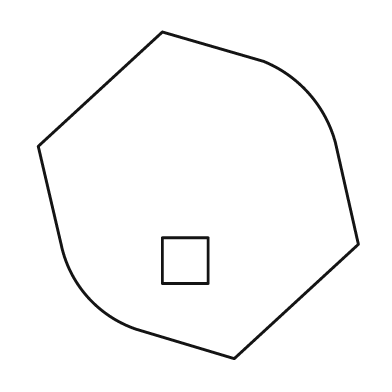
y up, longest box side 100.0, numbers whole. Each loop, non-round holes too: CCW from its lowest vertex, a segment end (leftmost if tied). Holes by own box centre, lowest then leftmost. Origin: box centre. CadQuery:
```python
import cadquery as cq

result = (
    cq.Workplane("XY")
    .moveTo(11.0, -50.0)
    .lineTo(49.0, -15.0)
    .lineTo(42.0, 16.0)
    .threePointArc((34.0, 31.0), (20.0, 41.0))
    .lineTo(-11.0, 50.0)
    .lineTo(-49.0, 15.0)
    .lineTo(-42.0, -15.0)
    .threePointArc((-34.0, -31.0), (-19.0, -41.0))
    .close()
    .moveTo(-11.0, -27.0)
    .lineTo(3.0, -27.0)
    .lineTo(3.0, -13.0)
    .lineTo(-11.0, -13.0)
    .close()
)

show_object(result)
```